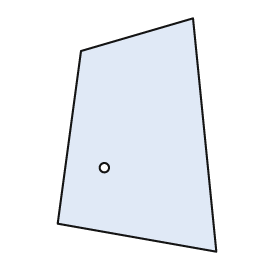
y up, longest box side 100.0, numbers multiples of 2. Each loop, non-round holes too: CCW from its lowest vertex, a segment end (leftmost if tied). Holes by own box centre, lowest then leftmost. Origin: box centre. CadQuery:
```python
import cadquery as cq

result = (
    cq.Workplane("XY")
    .moveTo(34.0, -50.0)
    .lineTo(24.0, 50.0)
    .lineTo(-24.0, 36.0)
    .lineTo(-34.0, -38.0)
    .close()
    .moveTo(-14.0, -14.0)
    .circle(2.0)
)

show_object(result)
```